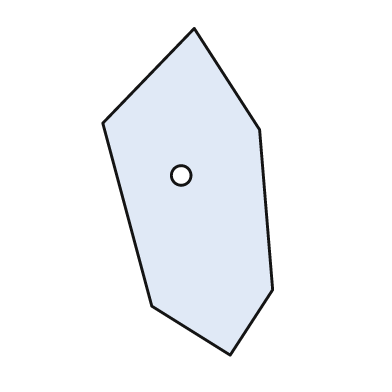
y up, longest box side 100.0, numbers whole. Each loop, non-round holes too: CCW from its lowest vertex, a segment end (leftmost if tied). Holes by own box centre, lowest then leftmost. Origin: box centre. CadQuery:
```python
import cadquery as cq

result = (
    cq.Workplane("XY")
    .moveTo(13.0, -50.0)
    .lineTo(26.0, -30.0)
    .lineTo(22.0, 19.0)
    .lineTo(2.0, 50.0)
    .lineTo(-26.0, 21.0)
    .lineTo(-11.0, -35.0)
    .close()
    .moveTo(-2.0, 5.0)
    .circle(3.0)
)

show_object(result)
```